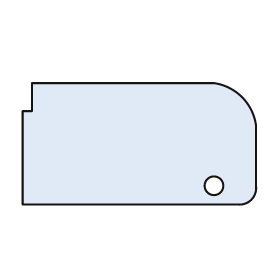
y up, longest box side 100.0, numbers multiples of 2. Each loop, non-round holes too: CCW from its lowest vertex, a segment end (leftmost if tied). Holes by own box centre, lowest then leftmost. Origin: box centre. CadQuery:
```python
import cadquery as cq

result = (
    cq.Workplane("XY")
    .moveTo(-50.0, -26.0)
    .lineTo(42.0, -26.0)
    .threePointArc((48.0, -24.0), (50.0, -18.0))
    .lineTo(50.0, 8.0)
    .threePointArc((44.0, 20.0), (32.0, 26.0))
    .lineTo(-46.0, 26.0)
    .lineTo(-46.0, 14.0)
    .lineTo(-50.0, 14.0)
    .close()
    .moveTo(32.0, -18.0)
    .circle(4.0)
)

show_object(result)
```